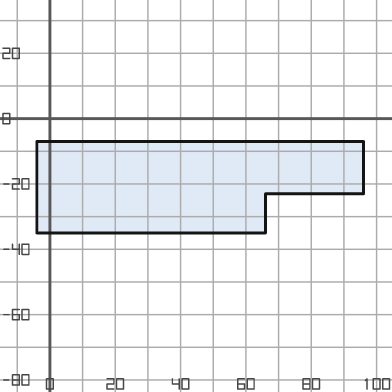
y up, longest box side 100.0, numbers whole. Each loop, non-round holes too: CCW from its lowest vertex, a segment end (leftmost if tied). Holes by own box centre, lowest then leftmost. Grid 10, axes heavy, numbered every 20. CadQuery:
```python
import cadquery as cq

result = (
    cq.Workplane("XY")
    .moveTo(-4.0, -35.0)
    .lineTo(66.0, -35.0)
    .lineTo(66.0, -23.0)
    .lineTo(96.0, -23.0)
    .lineTo(96.0, -7.0)
    .lineTo(-4.0, -7.0)
    .close()
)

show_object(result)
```